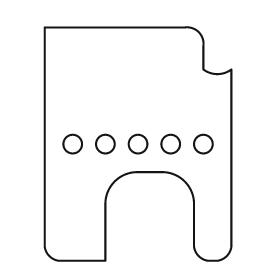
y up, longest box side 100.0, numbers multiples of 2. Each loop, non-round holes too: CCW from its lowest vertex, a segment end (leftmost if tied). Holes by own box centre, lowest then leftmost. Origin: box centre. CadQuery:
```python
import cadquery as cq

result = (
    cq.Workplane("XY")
    .moveTo(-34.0, -50.0)
    .lineTo(-14.0, -50.0)
    .lineTo(-14.0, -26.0)
    .threePointArc((-10.0, -16.0), (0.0, -12.0))
    .lineTo(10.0, -12.0)
    .threePointArc((20.0, -16.0), (24.0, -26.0))
    .lineTo(24.0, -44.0)
    .threePointArc((26.0, -48.0), (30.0, -50.0))
    .lineTo(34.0, -50.0)
    .threePointArc((38.0, -48.0), (40.0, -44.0))
    .lineTo(40.0, 32.0)
    .threePointArc((34.0, 30.0), (28.0, 32.0))
    .lineTo(28.0, 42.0)
    .threePointArc((26.0, 48.0), (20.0, 50.0))
    .lineTo(-40.0, 50.0)
    .lineTo(-40.0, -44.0)
    .threePointArc((-38.0, -48.0), (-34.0, -50.0))
    .close()
    .moveTo(-28.0, 0.0)
    .circle(4.0)
    .moveTo(-14.0, 0.0)
    .circle(4.0)
    .moveTo(0.0, 0.0)
    .circle(4.0)
    .moveTo(14.0, 0.0)
    .circle(4.0)
    .moveTo(28.0, 0.0)
    .circle(4.0)
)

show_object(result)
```